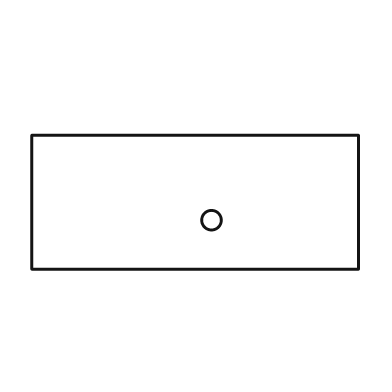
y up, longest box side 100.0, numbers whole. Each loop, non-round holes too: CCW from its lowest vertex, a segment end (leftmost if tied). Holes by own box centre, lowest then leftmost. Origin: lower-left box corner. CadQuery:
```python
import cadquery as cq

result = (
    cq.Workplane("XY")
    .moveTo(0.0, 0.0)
    .lineTo(100.0, 0.0)
    .lineTo(100.0, 41.0)
    .lineTo(0.0, 41.0)
    .close()
    .moveTo(55.0, 15.0)
    .circle(3.0)
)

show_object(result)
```